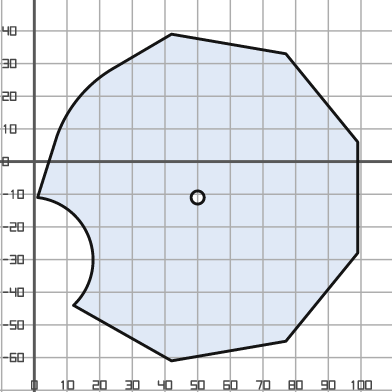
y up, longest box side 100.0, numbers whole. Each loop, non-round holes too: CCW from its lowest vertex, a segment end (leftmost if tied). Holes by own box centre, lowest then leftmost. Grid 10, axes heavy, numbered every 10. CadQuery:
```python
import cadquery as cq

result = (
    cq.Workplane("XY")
    .moveTo(42.0, -61.0)
    .lineTo(77.0, -55.0)
    .lineTo(99.0, -28.0)
    .lineTo(99.0, 6.0)
    .lineTo(77.0, 33.0)
    .lineTo(42.0, 39.0)
    .lineTo(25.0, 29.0)
    .threePointArc((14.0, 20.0), (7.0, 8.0))
    .lineTo(1.0, -11.0)
    .threePointArc((17.0, -24.0), (12.0, -44.0))
    .close()
    .moveTo(50.0, -11.0)
    .circle(2.0)
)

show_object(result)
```